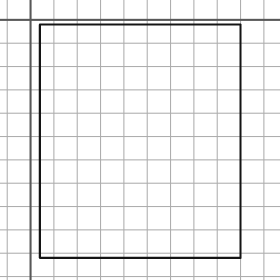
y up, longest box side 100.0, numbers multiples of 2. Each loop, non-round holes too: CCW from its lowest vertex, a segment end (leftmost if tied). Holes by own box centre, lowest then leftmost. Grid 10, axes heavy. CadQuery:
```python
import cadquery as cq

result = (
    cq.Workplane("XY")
    .moveTo(4.0, -102.0)
    .lineTo(90.0, -102.0)
    .lineTo(90.0, -2.0)
    .lineTo(4.0, -2.0)
    .close()
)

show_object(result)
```